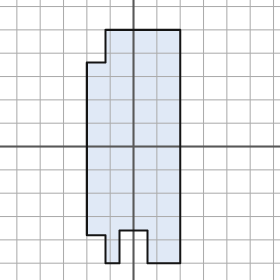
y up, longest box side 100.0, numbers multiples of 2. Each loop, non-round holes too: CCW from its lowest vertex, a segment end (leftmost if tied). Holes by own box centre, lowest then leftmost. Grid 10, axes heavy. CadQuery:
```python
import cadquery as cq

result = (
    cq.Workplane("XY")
    .moveTo(-12.0, -50.0)
    .lineTo(-6.0, -50.0)
    .lineTo(-6.0, -36.0)
    .lineTo(6.0, -36.0)
    .lineTo(6.0, -50.0)
    .lineTo(20.0, -50.0)
    .lineTo(20.0, 50.0)
    .lineTo(-12.0, 50.0)
    .lineTo(-12.0, 36.0)
    .lineTo(-20.0, 36.0)
    .lineTo(-20.0, -38.0)
    .lineTo(-12.0, -38.0)
    .close()
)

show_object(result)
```